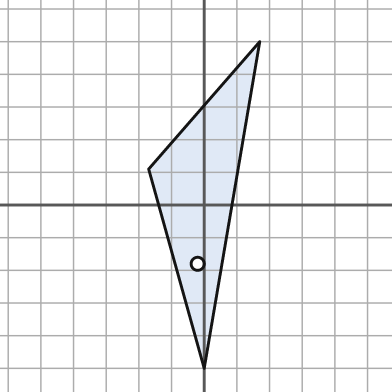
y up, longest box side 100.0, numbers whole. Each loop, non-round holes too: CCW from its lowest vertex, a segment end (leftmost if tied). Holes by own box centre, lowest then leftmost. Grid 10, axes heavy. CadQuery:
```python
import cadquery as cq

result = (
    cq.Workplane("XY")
    .moveTo(0.0, -50.0)
    .lineTo(17.0, 50.0)
    .lineTo(-17.0, 11.0)
    .close()
    .moveTo(-2.0, -18.0)
    .circle(2.0)
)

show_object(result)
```